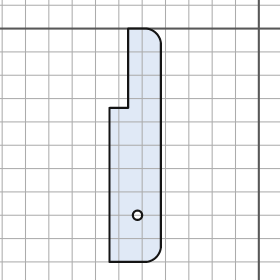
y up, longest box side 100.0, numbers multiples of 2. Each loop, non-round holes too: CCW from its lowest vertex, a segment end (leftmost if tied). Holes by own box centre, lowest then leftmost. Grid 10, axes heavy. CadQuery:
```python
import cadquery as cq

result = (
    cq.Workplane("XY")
    .moveTo(-64.0, -100.0)
    .lineTo(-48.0, -100.0)
    .threePointArc((-44.0, -98.0), (-42.0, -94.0))
    .lineTo(-42.0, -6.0)
    .threePointArc((-44.0, -2.0), (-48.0, 0.0))
    .lineTo(-56.0, 0.0)
    .lineTo(-56.0, -34.0)
    .lineTo(-64.0, -34.0)
    .close()
    .moveTo(-52.0, -80.0)
    .circle(2.0)
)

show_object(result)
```